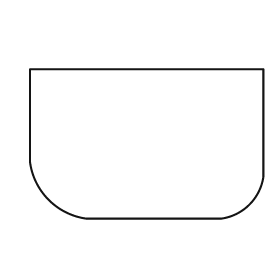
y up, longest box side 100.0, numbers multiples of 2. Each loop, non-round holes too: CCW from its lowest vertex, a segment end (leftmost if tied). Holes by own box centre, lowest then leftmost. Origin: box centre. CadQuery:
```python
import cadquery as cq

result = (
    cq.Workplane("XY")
    .moveTo(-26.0, -32.0)
    .lineTo(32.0, -32.0)
    .threePointArc((44.0, -26.0), (50.0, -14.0))
    .lineTo(50.0, 32.0)
    .lineTo(-50.0, 32.0)
    .lineTo(-50.0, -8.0)
    .threePointArc((-42.0, -24.0), (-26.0, -32.0))
    .close()
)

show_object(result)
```